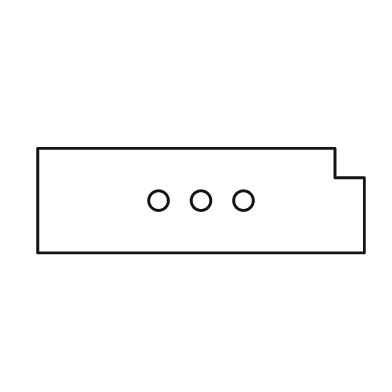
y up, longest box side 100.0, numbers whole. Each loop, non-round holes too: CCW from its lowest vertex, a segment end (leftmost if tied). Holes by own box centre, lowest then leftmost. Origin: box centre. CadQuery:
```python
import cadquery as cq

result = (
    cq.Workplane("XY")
    .moveTo(-50.0, -16.0)
    .lineTo(50.0, -16.0)
    .lineTo(50.0, 7.0)
    .lineTo(41.0, 7.0)
    .lineTo(41.0, 16.0)
    .lineTo(-50.0, 16.0)
    .close()
    .moveTo(-13.0, 0.0)
    .circle(3.0)
    .moveTo(0.0, 0.0)
    .circle(3.0)
    .moveTo(13.0, 0.0)
    .circle(3.0)
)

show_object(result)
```